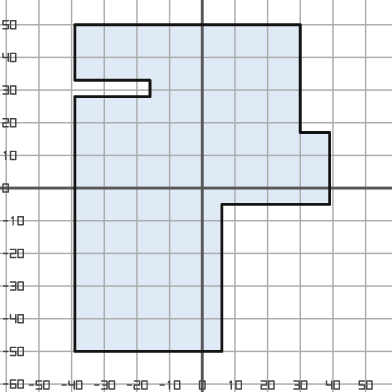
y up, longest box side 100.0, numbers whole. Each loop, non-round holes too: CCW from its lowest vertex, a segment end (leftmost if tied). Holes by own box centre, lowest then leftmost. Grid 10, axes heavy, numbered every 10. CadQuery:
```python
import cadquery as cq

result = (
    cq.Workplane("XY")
    .moveTo(-39.0, -50.0)
    .lineTo(6.0, -50.0)
    .lineTo(6.0, -5.0)
    .lineTo(39.0, -5.0)
    .lineTo(39.0, 17.0)
    .lineTo(30.0, 17.0)
    .lineTo(30.0, 50.0)
    .lineTo(-39.0, 50.0)
    .lineTo(-39.0, 33.0)
    .lineTo(-16.0, 33.0)
    .lineTo(-16.0, 28.0)
    .lineTo(-39.0, 28.0)
    .close()
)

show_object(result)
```